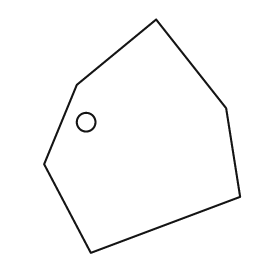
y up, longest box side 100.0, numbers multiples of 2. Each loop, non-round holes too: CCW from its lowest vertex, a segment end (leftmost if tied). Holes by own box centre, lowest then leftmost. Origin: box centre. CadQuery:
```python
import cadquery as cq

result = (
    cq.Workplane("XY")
    .moveTo(-22.0, -50.0)
    .lineTo(42.0, -26.0)
    .lineTo(36.0, 12.0)
    .lineTo(6.0, 50.0)
    .lineTo(-28.0, 22.0)
    .lineTo(-42.0, -12.0)
    .close()
    .moveTo(-24.0, 6.0)
    .circle(4.0)
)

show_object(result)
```